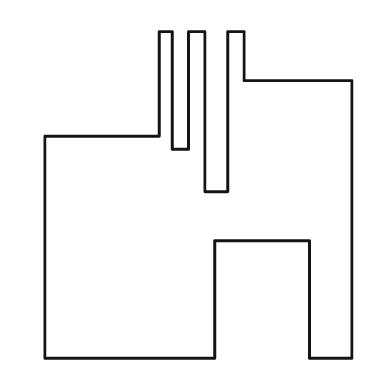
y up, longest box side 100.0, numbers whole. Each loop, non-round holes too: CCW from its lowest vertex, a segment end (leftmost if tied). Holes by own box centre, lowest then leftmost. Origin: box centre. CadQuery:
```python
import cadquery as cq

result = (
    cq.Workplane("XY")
    .moveTo(-47.0, -50.0)
    .lineTo(5.0, -50.0)
    .lineTo(5.0, -14.0)
    .lineTo(34.0, -14.0)
    .lineTo(34.0, -50.0)
    .lineTo(47.0, -50.0)
    .lineTo(47.0, 35.0)
    .lineTo(14.0, 35.0)
    .lineTo(14.0, 50.0)
    .lineTo(9.0, 50.0)
    .lineTo(9.0, 1.0)
    .lineTo(2.0, 1.0)
    .lineTo(2.0, 50.0)
    .lineTo(-3.0, 50.0)
    .lineTo(-3.0, 14.0)
    .lineTo(-8.0, 14.0)
    .lineTo(-8.0, 50.0)
    .lineTo(-12.0, 50.0)
    .lineTo(-12.0, 18.0)
    .lineTo(-47.0, 18.0)
    .close()
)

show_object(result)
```